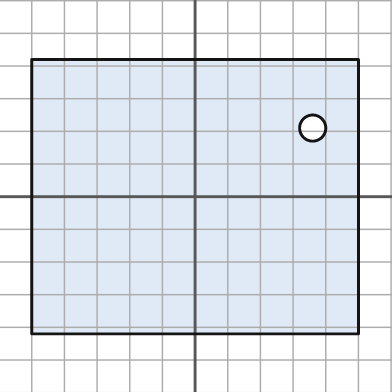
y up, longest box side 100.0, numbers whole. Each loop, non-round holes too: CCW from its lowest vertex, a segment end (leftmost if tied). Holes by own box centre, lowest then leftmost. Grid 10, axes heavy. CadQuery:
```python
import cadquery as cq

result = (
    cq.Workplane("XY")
    .moveTo(-50.0, -42.0)
    .lineTo(50.0, -42.0)
    .lineTo(50.0, 42.0)
    .lineTo(-50.0, 42.0)
    .close()
    .moveTo(36.0, 21.0)
    .circle(4.0)
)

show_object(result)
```